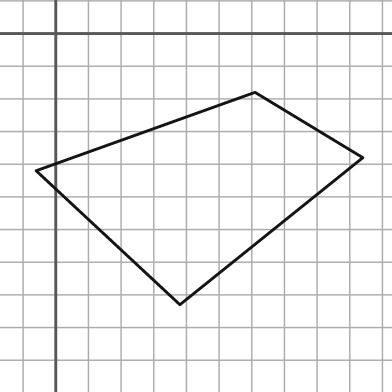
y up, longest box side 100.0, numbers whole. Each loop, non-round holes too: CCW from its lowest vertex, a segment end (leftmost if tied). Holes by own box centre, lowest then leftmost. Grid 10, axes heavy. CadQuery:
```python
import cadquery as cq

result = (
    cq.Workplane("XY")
    .moveTo(38.0, -83.0)
    .lineTo(94.0, -38.0)
    .lineTo(61.0, -18.0)
    .lineTo(-6.0, -42.0)
    .close()
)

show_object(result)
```